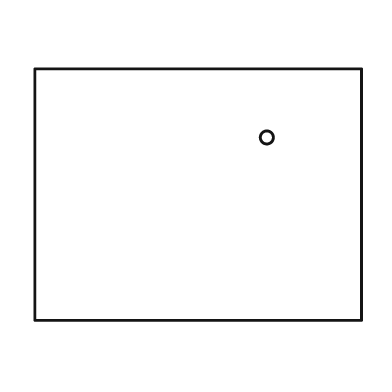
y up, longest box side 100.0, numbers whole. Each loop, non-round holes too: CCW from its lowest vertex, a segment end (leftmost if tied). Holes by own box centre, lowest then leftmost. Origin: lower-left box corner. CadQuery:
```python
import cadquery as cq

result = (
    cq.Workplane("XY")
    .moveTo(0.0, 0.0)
    .lineTo(100.0, 0.0)
    .lineTo(100.0, 77.0)
    .lineTo(0.0, 77.0)
    .close()
    .moveTo(71.0, 56.0)
    .circle(2.0)
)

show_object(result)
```